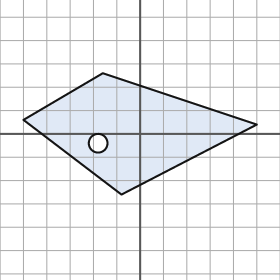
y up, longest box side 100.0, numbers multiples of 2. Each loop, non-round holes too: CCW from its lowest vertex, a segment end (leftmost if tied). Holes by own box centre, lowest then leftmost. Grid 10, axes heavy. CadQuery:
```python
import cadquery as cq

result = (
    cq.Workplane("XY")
    .moveTo(-8.0, -26.0)
    .lineTo(50.0, 4.0)
    .lineTo(-16.0, 26.0)
    .lineTo(-50.0, 6.0)
    .close()
    .moveTo(-18.0, -4.0)
    .circle(4.0)
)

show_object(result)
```